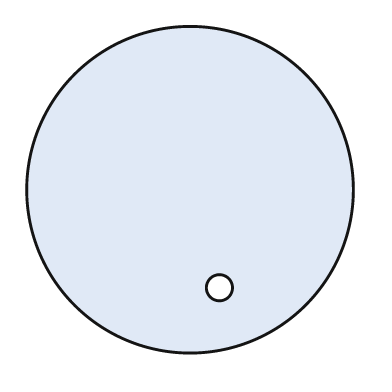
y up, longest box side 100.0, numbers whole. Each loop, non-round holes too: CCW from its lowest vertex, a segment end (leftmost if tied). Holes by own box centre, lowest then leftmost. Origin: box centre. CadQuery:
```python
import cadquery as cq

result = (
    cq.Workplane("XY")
    .moveTo(0.0, 0.0)
    .circle(50.0)
    .moveTo(9.0, -30.0)
    .circle(4.0)
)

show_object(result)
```